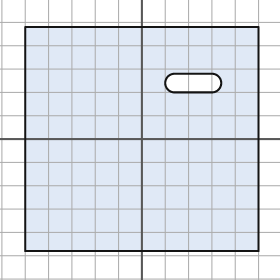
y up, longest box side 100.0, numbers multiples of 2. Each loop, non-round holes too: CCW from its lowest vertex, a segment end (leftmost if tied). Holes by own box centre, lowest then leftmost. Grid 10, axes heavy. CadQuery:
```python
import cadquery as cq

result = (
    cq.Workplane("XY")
    .moveTo(-50.0, -48.0)
    .lineTo(50.0, -48.0)
    .lineTo(50.0, 48.0)
    .lineTo(-50.0, 48.0)
    .close()
    .moveTo(14.0, 20.0)
    .lineTo(30.0, 20.0)
    .threePointArc((34.0, 24.0), (30.0, 28.0))
    .lineTo(14.0, 28.0)
    .threePointArc((10.0, 24.0), (14.0, 20.0))
    .close()
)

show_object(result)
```